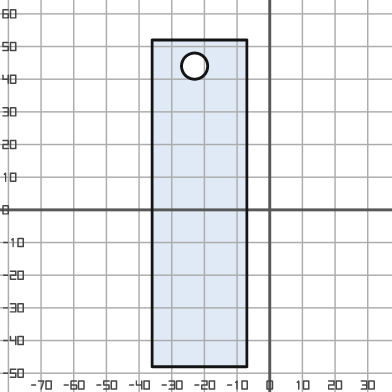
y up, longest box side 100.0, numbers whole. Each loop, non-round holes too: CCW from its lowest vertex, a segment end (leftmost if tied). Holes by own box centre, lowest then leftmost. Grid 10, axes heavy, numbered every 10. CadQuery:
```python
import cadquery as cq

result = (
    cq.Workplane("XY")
    .moveTo(-36.0, -48.0)
    .lineTo(-7.0, -48.0)
    .lineTo(-7.0, 52.0)
    .lineTo(-36.0, 52.0)
    .close()
    .moveTo(-23.0, 44.0)
    .circle(4.0)
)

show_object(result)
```